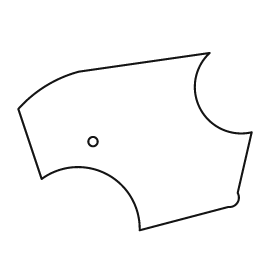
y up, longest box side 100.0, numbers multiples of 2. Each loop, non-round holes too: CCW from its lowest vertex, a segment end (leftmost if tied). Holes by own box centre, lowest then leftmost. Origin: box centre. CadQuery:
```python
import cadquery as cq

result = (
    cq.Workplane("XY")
    .moveTo(2.0, -38.0)
    .lineTo(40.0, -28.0)
    .threePointArc((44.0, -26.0), (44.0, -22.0))
    .lineTo(50.0, 4.0)
    .threePointArc((28.0, 14.0), (32.0, 38.0))
    .lineTo(-24.0, 30.0)
    .threePointArc((-38.0, 24.0), (-50.0, 14.0))
    .lineTo(-40.0, -16.0)
    .threePointArc((-12.0, -14.0), (2.0, -38.0))
    .close()
    .moveTo(-18.0, 0.0)
    .circle(2.0)
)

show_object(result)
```